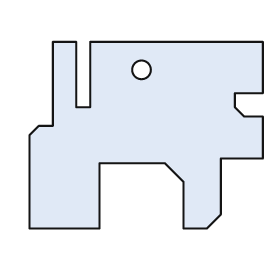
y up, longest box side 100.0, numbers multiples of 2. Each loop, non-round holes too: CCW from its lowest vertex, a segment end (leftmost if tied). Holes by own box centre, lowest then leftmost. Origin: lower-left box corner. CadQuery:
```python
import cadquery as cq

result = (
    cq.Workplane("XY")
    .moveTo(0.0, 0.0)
    .lineTo(30.0, 0.0)
    .lineTo(30.0, 28.0)
    .lineTo(58.0, 28.0)
    .lineTo(66.0, 20.0)
    .lineTo(66.0, 0.0)
    .lineTo(76.0, 0.0)
    .lineTo(82.0, 6.0)
    .lineTo(82.0, 30.0)
    .lineTo(100.0, 30.0)
    .lineTo(100.0, 48.0)
    .lineTo(92.0, 48.0)
    .lineTo(88.0, 52.0)
    .lineTo(88.0, 58.0)
    .lineTo(100.0, 58.0)
    .lineTo(100.0, 80.0)
    .lineTo(26.0, 80.0)
    .lineTo(26.0, 52.0)
    .lineTo(20.0, 52.0)
    .lineTo(20.0, 80.0)
    .lineTo(10.0, 80.0)
    .lineTo(10.0, 44.0)
    .lineTo(4.0, 44.0)
    .lineTo(0.0, 40.0)
    .close()
    .moveTo(48.0, 68.0)
    .circle(4.0)
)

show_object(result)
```